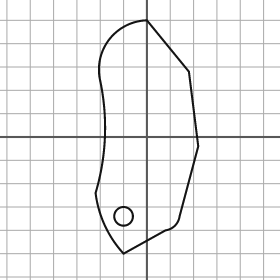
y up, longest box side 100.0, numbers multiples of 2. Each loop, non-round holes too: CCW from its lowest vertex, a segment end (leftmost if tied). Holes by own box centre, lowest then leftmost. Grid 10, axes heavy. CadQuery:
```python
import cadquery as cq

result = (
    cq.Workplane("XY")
    .moveTo(-10.0, -50.0)
    .lineTo(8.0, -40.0)
    .threePointArc((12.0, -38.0), (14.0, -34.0))
    .lineTo(22.0, -4.0)
    .lineTo(18.0, 28.0)
    .lineTo(0.0, 50.0)
    .threePointArc((-16.0, 42.0), (-20.0, 24.0))
    .threePointArc((-18.0, 0.0), (-22.0, -24.0))
    .threePointArc((-18.0, -38.0), (-10.0, -50.0))
    .close()
    .moveTo(-10.0, -34.0)
    .circle(4.0)
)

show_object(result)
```